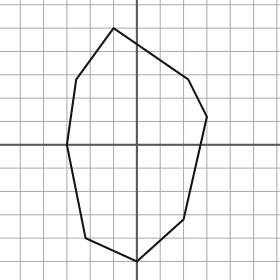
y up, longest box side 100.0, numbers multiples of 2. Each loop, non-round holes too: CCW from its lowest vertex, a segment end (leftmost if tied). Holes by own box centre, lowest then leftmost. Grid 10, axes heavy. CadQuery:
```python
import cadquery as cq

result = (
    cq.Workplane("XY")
    .moveTo(0.0, -50.0)
    .lineTo(20.0, -32.0)
    .lineTo(30.0, 12.0)
    .lineTo(22.0, 28.0)
    .lineTo(-10.0, 50.0)
    .lineTo(-26.0, 28.0)
    .lineTo(-30.0, 0.0)
    .lineTo(-22.0, -40.0)
    .close()
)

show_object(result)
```